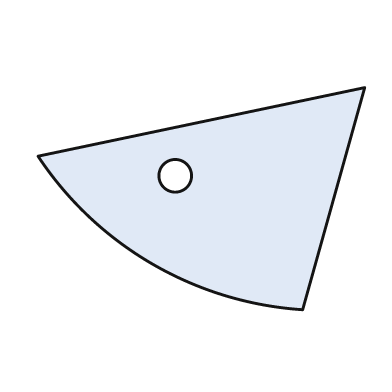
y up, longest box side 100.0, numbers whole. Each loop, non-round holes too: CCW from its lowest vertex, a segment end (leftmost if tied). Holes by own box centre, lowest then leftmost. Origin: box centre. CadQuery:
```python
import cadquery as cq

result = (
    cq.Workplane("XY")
    .moveTo(31.0, -34.0)
    .lineTo(50.0, 34.0)
    .lineTo(-50.0, 13.0)
    .threePointArc((-15.0, -20.0), (31.0, -34.0))
    .close()
    .moveTo(-8.0, 7.0)
    .circle(5.0)
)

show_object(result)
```